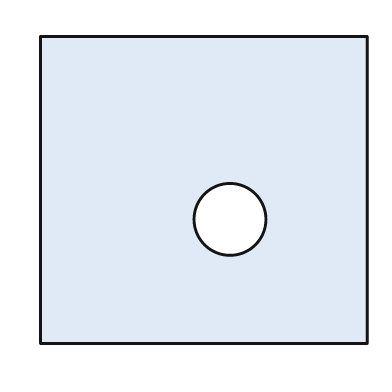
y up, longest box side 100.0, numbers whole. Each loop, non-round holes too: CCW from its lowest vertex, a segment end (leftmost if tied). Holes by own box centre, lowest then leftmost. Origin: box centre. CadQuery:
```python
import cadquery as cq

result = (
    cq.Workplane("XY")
    .moveTo(-50.0, -47.0)
    .lineTo(50.0, -47.0)
    .lineTo(50.0, 47.0)
    .lineTo(-50.0, 47.0)
    .close()
    .moveTo(8.0, -9.0)
    .circle(11.0)
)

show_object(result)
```